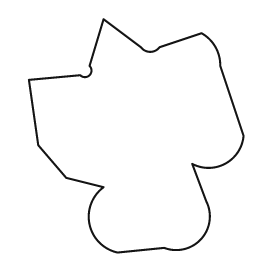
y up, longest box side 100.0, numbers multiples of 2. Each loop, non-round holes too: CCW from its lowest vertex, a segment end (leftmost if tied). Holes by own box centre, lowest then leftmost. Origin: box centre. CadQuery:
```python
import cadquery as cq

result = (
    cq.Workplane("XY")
    .moveTo(-8.0, -50.0)
    .lineTo(12.0, -48.0)
    .threePointArc((28.0, -44.0), (30.0, -28.0))
    .lineTo(24.0, -12.0)
    .threePointArc((38.0, -12.0), (46.0, 0.0))
    .lineTo(36.0, 30.0)
    .threePointArc((34.0, 38.0), (28.0, 44.0))
    .lineTo(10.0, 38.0)
    .threePointArc((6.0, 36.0), (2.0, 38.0))
    .lineTo(-14.0, 50.0)
    .lineTo(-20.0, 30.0)
    .threePointArc((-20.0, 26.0), (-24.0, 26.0))
    .lineTo(-46.0, 24.0)
    .lineTo(-42.0, -4.0)
    .lineTo(-30.0, -18.0)
    .lineTo(-14.0, -22.0)
    .threePointArc((-20.0, -38.0), (-8.0, -50.0))
    .close()
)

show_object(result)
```